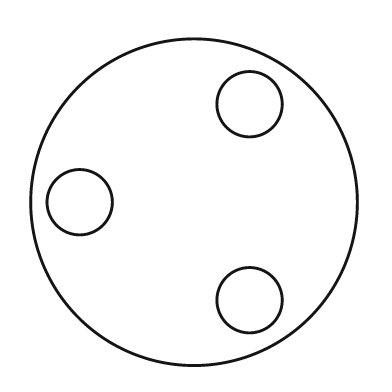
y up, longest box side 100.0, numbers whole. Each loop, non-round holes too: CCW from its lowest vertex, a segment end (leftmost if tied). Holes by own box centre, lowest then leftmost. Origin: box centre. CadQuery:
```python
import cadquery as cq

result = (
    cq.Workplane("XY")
    .moveTo(0.0, 0.0)
    .circle(50.0)
    .moveTo(17.0, -30.0)
    .circle(10.0)
    .moveTo(-35.0, 0.0)
    .circle(10.0)
    .moveTo(17.0, 30.0)
    .circle(10.0)
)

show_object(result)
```